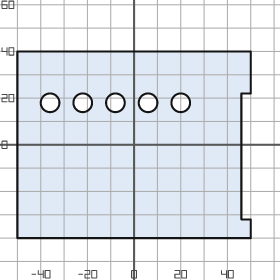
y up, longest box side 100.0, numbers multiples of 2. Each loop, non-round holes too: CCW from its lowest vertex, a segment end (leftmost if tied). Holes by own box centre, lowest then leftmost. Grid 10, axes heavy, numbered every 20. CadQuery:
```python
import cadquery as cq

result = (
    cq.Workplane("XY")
    .moveTo(-50.0, -40.0)
    .lineTo(50.0, -40.0)
    .lineTo(50.0, -32.0)
    .lineTo(46.0, -32.0)
    .lineTo(46.0, 22.0)
    .lineTo(50.0, 22.0)
    .lineTo(50.0, 40.0)
    .lineTo(-50.0, 40.0)
    .close()
    .moveTo(-36.0, 18.0)
    .circle(4.0)
    .moveTo(-22.0, 18.0)
    .circle(4.0)
    .moveTo(-8.0, 18.0)
    .circle(4.0)
    .moveTo(6.0, 18.0)
    .circle(4.0)
    .moveTo(20.0, 18.0)
    .circle(4.0)
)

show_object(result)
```